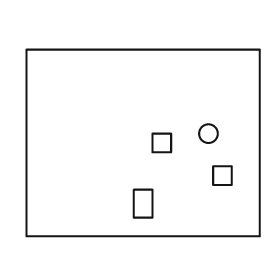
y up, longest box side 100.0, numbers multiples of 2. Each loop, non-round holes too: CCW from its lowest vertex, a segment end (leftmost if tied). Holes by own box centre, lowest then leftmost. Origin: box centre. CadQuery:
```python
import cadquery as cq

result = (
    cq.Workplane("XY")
    .moveTo(-50.0, -40.0)
    .lineTo(50.0, -40.0)
    .lineTo(50.0, 40.0)
    .lineTo(-50.0, 40.0)
    .close()
    .moveTo(-4.0, -32.0)
    .lineTo(4.0, -32.0)
    .lineTo(4.0, -20.0)
    .lineTo(-4.0, -20.0)
    .close()
    .moveTo(30.0, -18.0)
    .lineTo(38.0, -18.0)
    .lineTo(38.0, -10.0)
    .lineTo(30.0, -10.0)
    .close()
    .moveTo(4.0, -4.0)
    .lineTo(12.0, -4.0)
    .lineTo(12.0, 4.0)
    .lineTo(4.0, 4.0)
    .close()
    .moveTo(28.0, 4.0)
    .circle(4.0)
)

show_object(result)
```